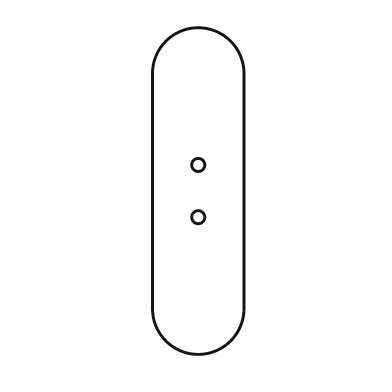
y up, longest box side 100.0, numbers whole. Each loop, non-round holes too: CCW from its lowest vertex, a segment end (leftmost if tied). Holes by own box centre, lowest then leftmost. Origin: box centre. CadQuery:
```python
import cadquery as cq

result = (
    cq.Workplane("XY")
    .moveTo(-14.0, -36.0)
    .threePointArc((0.0, -50.0), (14.0, -36.0))
    .lineTo(14.0, 36.0)
    .threePointArc((0.0, 50.0), (-14.0, 36.0))
    .close()
    .moveTo(0.0, -8.0)
    .circle(2.0)
    .moveTo(0.0, 8.0)
    .circle(2.0)
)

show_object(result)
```